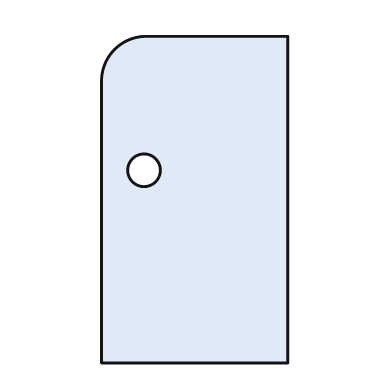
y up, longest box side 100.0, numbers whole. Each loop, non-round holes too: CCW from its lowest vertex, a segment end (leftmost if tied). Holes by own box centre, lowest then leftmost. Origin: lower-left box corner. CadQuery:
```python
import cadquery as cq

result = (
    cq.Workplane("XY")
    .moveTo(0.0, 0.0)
    .lineTo(57.0, 0.0)
    .lineTo(57.0, 100.0)
    .lineTo(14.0, 100.0)
    .threePointArc((4.0, 96.0), (0.0, 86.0))
    .close()
    .moveTo(13.0, 59.0)
    .circle(5.0)
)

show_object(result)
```